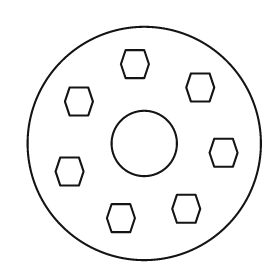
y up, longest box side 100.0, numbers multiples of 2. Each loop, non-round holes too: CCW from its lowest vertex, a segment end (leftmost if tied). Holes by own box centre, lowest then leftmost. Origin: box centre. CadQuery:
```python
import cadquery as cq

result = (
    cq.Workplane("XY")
    .moveTo(0.0, 0.0)
    .circle(50.0)
    .moveTo(-14.0, -38.0)
    .lineTo(-6.0, -38.0)
    .lineTo(-4.0, -32.0)
    .lineTo(-6.0, -26.0)
    .lineTo(-14.0, -26.0)
    .lineTo(-16.0, -32.0)
    .close()
    .moveTo(14.0, -34.0)
    .lineTo(22.0, -34.0)
    .lineTo(24.0, -28.0)
    .lineTo(22.0, -22.0)
    .lineTo(14.0, -22.0)
    .lineTo(12.0, -28.0)
    .close()
    .moveTo(-36.0, -18.0)
    .lineTo(-28.0, -18.0)
    .lineTo(-26.0, -12.0)
    .lineTo(-28.0, -6.0)
    .lineTo(-36.0, -6.0)
    .lineTo(-38.0, -12.0)
    .close()
    .moveTo(30.0, -10.0)
    .lineTo(38.0, -10.0)
    .lineTo(40.0, -4.0)
    .lineTo(38.0, 2.0)
    .lineTo(30.0, 2.0)
    .lineTo(28.0, -4.0)
    .close()
    .moveTo(0.0, 0.0)
    .circle(14.0)
    .moveTo(-32.0, 12.0)
    .lineTo(-24.0, 12.0)
    .lineTo(-22.0, 18.0)
    .lineTo(-24.0, 24.0)
    .lineTo(-32.0, 24.0)
    .lineTo(-34.0, 18.0)
    .close()
    .moveTo(20.0, 18.0)
    .lineTo(28.0, 18.0)
    .lineTo(30.0, 24.0)
    .lineTo(28.0, 30.0)
    .lineTo(20.0, 30.0)
    .lineTo(18.0, 24.0)
    .close()
    .moveTo(-8.0, 28.0)
    .lineTo(0.0, 28.0)
    .lineTo(2.0, 34.0)
    .lineTo(0.0, 40.0)
    .lineTo(-8.0, 40.0)
    .lineTo(-10.0, 34.0)
    .close()
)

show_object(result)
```